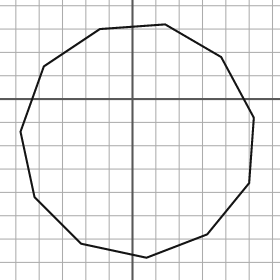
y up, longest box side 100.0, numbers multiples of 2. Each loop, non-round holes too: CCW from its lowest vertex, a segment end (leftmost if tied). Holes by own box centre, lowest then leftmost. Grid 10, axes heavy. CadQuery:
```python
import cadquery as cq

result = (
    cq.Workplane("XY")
    .moveTo(6.0, -68.0)
    .lineTo(32.0, -58.0)
    .lineTo(50.0, -36.0)
    .lineTo(52.0, -8.0)
    .lineTo(38.0, 18.0)
    .lineTo(14.0, 32.0)
    .lineTo(-14.0, 30.0)
    .lineTo(-38.0, 14.0)
    .lineTo(-48.0, -14.0)
    .lineTo(-42.0, -42.0)
    .lineTo(-22.0, -62.0)
    .close()
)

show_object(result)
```